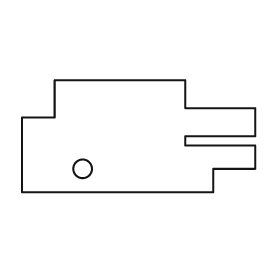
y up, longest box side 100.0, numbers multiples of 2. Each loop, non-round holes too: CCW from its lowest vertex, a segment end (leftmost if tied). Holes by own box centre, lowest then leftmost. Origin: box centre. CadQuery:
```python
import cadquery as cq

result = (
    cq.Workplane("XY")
    .moveTo(-50.0, -24.0)
    .lineTo(32.0, -24.0)
    .lineTo(32.0, -14.0)
    .lineTo(50.0, -14.0)
    .lineTo(50.0, -4.0)
    .lineTo(20.0, -4.0)
    .lineTo(20.0, 0.0)
    .lineTo(50.0, 0.0)
    .lineTo(50.0, 12.0)
    .lineTo(20.0, 12.0)
    .lineTo(20.0, 24.0)
    .lineTo(-36.0, 24.0)
    .lineTo(-36.0, 8.0)
    .lineTo(-50.0, 8.0)
    .close()
    .moveTo(-24.0, -14.0)
    .circle(4.0)
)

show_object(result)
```